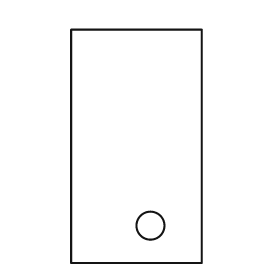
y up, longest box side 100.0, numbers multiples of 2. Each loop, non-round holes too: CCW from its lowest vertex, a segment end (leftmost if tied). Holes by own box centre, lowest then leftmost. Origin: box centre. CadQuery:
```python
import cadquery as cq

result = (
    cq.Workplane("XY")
    .moveTo(-28.0, -50.0)
    .lineTo(28.0, -50.0)
    .lineTo(28.0, 50.0)
    .lineTo(-28.0, 50.0)
    .close()
    .moveTo(6.0, -34.0)
    .circle(6.0)
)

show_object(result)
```